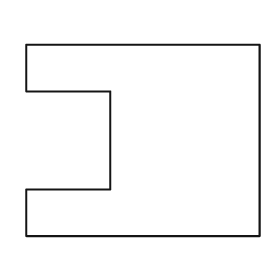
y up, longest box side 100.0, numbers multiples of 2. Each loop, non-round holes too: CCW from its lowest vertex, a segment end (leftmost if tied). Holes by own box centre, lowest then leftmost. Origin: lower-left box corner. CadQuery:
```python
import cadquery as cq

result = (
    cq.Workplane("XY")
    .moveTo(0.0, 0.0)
    .lineTo(100.0, 0.0)
    .lineTo(100.0, 82.0)
    .lineTo(0.0, 82.0)
    .lineTo(0.0, 62.0)
    .lineTo(36.0, 62.0)
    .lineTo(36.0, 20.0)
    .lineTo(0.0, 20.0)
    .close()
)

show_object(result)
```